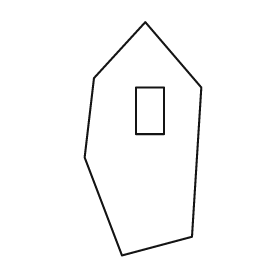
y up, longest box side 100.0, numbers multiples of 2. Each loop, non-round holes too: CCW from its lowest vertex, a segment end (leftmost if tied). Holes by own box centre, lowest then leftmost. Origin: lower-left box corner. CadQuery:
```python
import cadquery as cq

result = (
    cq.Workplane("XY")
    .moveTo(16.0, 0.0)
    .lineTo(46.0, 8.0)
    .lineTo(50.0, 72.0)
    .lineTo(26.0, 100.0)
    .lineTo(4.0, 76.0)
    .lineTo(0.0, 42.0)
    .close()
    .moveTo(22.0, 52.0)
    .lineTo(34.0, 52.0)
    .lineTo(34.0, 72.0)
    .lineTo(22.0, 72.0)
    .close()
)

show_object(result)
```